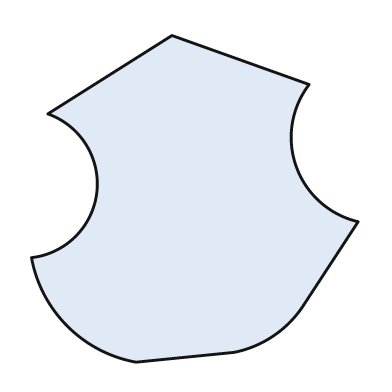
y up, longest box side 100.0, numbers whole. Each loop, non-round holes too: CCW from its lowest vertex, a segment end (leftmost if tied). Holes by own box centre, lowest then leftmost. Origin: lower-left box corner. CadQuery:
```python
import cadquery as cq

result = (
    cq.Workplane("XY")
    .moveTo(32.0, 0.0)
    .lineTo(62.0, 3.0)
    .threePointArc((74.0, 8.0), (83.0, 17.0))
    .lineTo(100.0, 43.0)
    .threePointArc((81.0, 60.0), (85.0, 85.0))
    .lineTo(43.0, 100.0)
    .lineTo(5.0, 76.0)
    .threePointArc((20.0, 52.0), (0.0, 32.0))
    .threePointArc((11.0, 11.0), (32.0, 0.0))
    .close()
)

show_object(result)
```